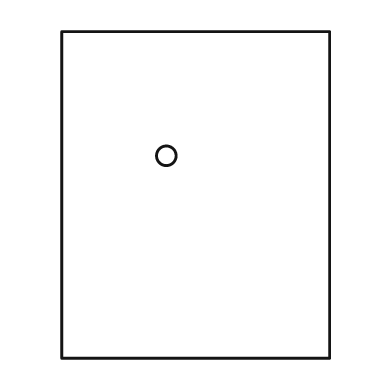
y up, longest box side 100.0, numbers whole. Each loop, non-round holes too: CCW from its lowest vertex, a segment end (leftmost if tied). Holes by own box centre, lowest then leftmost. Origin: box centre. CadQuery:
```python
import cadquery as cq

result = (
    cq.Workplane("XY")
    .moveTo(-41.0, -50.0)
    .lineTo(41.0, -50.0)
    .lineTo(41.0, 50.0)
    .lineTo(-41.0, 50.0)
    .close()
    .moveTo(-9.0, 12.0)
    .circle(3.0)
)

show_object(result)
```